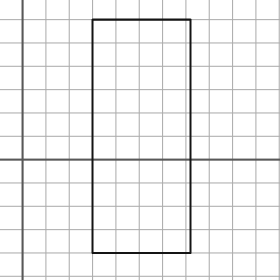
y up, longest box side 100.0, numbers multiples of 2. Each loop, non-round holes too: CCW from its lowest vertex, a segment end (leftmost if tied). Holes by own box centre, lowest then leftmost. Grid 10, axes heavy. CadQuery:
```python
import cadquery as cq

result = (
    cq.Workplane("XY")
    .moveTo(30.0, -40.0)
    .lineTo(72.0, -40.0)
    .lineTo(72.0, 60.0)
    .lineTo(30.0, 60.0)
    .close()
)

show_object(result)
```